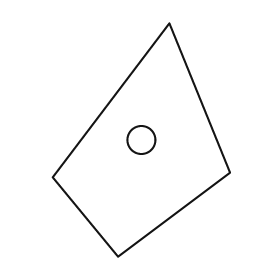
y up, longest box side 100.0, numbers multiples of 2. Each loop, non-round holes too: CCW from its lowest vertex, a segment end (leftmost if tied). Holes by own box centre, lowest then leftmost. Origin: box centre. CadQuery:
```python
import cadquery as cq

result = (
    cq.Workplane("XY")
    .moveTo(-10.0, -50.0)
    .lineTo(38.0, -14.0)
    .lineTo(12.0, 50.0)
    .lineTo(-38.0, -16.0)
    .close()
    .moveTo(0.0, 0.0)
    .circle(6.0)
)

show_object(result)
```